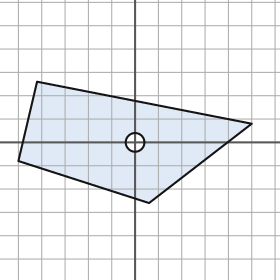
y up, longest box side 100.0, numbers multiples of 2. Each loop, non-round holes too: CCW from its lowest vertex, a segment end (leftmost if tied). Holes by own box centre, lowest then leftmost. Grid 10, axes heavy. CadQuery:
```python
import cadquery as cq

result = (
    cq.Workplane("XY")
    .moveTo(6.0, -26.0)
    .lineTo(50.0, 8.0)
    .lineTo(-42.0, 26.0)
    .lineTo(-50.0, -8.0)
    .close()
    .moveTo(0.0, 0.0)
    .circle(4.0)
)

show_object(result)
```